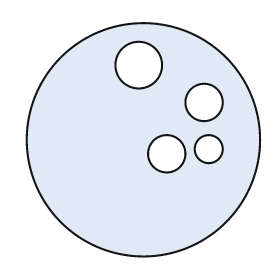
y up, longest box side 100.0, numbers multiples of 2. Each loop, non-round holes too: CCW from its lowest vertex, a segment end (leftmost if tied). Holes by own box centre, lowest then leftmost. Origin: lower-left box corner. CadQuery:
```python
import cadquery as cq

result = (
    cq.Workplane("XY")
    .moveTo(50.0, 50.0)
    .circle(50.0)
    .moveTo(60.0, 44.0)
    .circle(8.0)
    .moveTo(78.0, 46.0)
    .circle(6.0)
    .moveTo(76.0, 66.0)
    .circle(8.0)
    .moveTo(48.0, 82.0)
    .circle(10.0)
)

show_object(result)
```